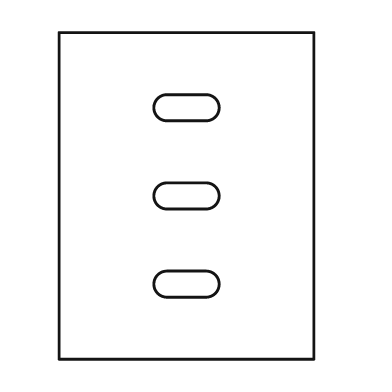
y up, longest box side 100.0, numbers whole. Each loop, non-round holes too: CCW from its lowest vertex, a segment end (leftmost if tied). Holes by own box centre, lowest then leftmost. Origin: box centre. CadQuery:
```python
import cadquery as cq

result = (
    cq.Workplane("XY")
    .moveTo(-39.0, -50.0)
    .lineTo(39.0, -50.0)
    .lineTo(39.0, 50.0)
    .lineTo(-39.0, 50.0)
    .close()
    .moveTo(-6.0, -31.0)
    .lineTo(6.0, -31.0)
    .threePointArc((10.0, -27.0), (6.0, -23.0))
    .lineTo(-6.0, -23.0)
    .threePointArc((-10.0, -27.0), (-6.0, -31.0))
    .close()
    .moveTo(-6.0, -4.0)
    .lineTo(6.0, -4.0)
    .threePointArc((10.0, 0.0), (6.0, 4.0))
    .lineTo(-6.0, 4.0)
    .threePointArc((-10.0, 0.0), (-6.0, -4.0))
    .close()
    .moveTo(-6.0, 23.0)
    .lineTo(6.0, 23.0)
    .threePointArc((10.0, 27.0), (6.0, 31.0))
    .lineTo(-6.0, 31.0)
    .threePointArc((-10.0, 27.0), (-6.0, 23.0))
    .close()
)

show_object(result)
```